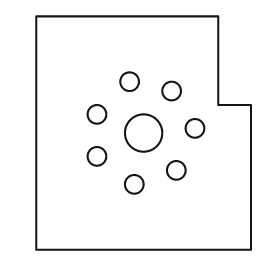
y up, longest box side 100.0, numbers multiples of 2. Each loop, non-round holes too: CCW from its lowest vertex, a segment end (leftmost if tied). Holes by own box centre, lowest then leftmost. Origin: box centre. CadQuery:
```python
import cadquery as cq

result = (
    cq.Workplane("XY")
    .moveTo(-46.0, -50.0)
    .lineTo(46.0, -50.0)
    .lineTo(46.0, 12.0)
    .lineTo(32.0, 12.0)
    .lineTo(32.0, 50.0)
    .lineTo(-46.0, 50.0)
    .close()
    .moveTo(-4.0, -22.0)
    .circle(4.0)
    .moveTo(14.0, -16.0)
    .circle(4.0)
    .moveTo(-20.0, -10.0)
    .circle(4.0)
    .moveTo(0.0, 0.0)
    .circle(8.0)
    .moveTo(22.0, 2.0)
    .circle(4.0)
    .moveTo(-20.0, 8.0)
    .circle(4.0)
    .moveTo(12.0, 18.0)
    .circle(4.0)
    .moveTo(-6.0, 22.0)
    .circle(4.0)
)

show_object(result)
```